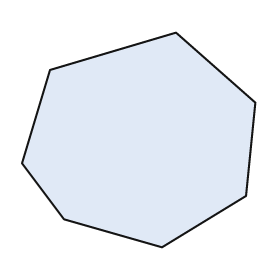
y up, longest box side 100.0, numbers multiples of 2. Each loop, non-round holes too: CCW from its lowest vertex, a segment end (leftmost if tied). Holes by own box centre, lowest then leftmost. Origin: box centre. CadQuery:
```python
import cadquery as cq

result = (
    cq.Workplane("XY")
    .moveTo(10.0, -46.0)
    .lineTo(46.0, -24.0)
    .lineTo(50.0, 16.0)
    .lineTo(16.0, 46.0)
    .lineTo(-38.0, 30.0)
    .lineTo(-50.0, -10.0)
    .lineTo(-32.0, -34.0)
    .close()
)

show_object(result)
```